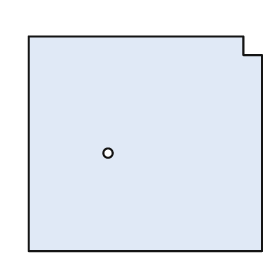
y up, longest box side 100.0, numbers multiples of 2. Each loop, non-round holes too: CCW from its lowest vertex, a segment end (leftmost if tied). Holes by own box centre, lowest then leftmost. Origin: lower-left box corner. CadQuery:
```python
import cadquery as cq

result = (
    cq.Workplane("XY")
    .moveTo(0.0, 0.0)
    .lineTo(100.0, 0.0)
    .lineTo(100.0, 84.0)
    .lineTo(92.0, 84.0)
    .lineTo(92.0, 92.0)
    .lineTo(0.0, 92.0)
    .close()
    .moveTo(34.0, 42.0)
    .circle(2.0)
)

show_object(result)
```